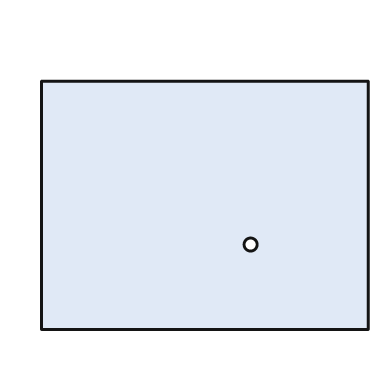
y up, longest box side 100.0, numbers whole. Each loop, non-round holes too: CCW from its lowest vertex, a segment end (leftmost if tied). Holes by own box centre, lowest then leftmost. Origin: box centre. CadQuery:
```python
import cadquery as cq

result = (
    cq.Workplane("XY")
    .moveTo(-50.0, -38.0)
    .lineTo(50.0, -38.0)
    .lineTo(50.0, 38.0)
    .lineTo(-50.0, 38.0)
    .close()
    .moveTo(14.0, -12.0)
    .circle(2.0)
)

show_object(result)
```